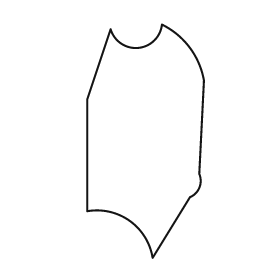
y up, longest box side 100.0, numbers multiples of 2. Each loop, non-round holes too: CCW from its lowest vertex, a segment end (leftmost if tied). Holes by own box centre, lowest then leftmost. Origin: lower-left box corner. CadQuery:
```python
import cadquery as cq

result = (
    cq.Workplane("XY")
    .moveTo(28.0, 0.0)
    .lineTo(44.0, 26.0)
    .threePointArc((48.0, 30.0), (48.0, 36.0))
    .lineTo(50.0, 76.0)
    .threePointArc((44.0, 90.0), (32.0, 100.0))
    .threePointArc((22.0, 90.0), (10.0, 98.0))
    .lineTo(0.0, 68.0)
    .lineTo(0.0, 20.0)
    .threePointArc((18.0, 16.0), (28.0, 0.0))
    .close()
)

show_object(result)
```